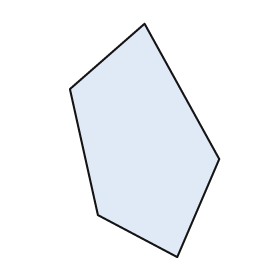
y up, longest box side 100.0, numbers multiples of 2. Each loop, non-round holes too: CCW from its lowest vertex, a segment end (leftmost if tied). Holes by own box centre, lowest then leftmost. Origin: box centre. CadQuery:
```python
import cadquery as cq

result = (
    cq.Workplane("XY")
    .moveTo(14.0, -50.0)
    .lineTo(32.0, -8.0)
    .lineTo(0.0, 50.0)
    .lineTo(-32.0, 22.0)
    .lineTo(-20.0, -32.0)
    .close()
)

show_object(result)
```